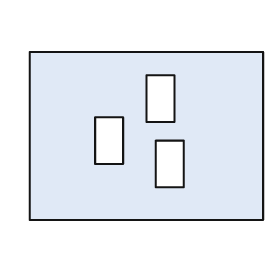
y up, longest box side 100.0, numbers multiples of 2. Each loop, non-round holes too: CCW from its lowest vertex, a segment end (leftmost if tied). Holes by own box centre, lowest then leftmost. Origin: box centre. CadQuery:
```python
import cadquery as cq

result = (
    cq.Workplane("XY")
    .moveTo(-50.0, -36.0)
    .lineTo(50.0, -36.0)
    .lineTo(50.0, 36.0)
    .lineTo(-50.0, 36.0)
    .close()
    .moveTo(4.0, -22.0)
    .lineTo(16.0, -22.0)
    .lineTo(16.0, -2.0)
    .lineTo(4.0, -2.0)
    .close()
    .moveTo(-22.0, -12.0)
    .lineTo(-10.0, -12.0)
    .lineTo(-10.0, 8.0)
    .lineTo(-22.0, 8.0)
    .close()
    .moveTo(0.0, 6.0)
    .lineTo(12.0, 6.0)
    .lineTo(12.0, 26.0)
    .lineTo(0.0, 26.0)
    .close()
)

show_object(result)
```